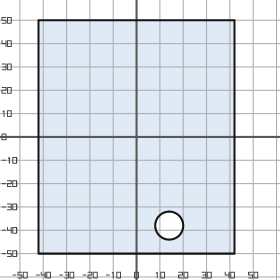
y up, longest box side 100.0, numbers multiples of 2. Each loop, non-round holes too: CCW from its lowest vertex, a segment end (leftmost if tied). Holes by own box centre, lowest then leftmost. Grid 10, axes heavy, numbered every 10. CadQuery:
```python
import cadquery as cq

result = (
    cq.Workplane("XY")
    .moveTo(-42.0, -50.0)
    .lineTo(42.0, -50.0)
    .lineTo(42.0, 50.0)
    .lineTo(-42.0, 50.0)
    .close()
    .moveTo(14.0, -38.0)
    .circle(6.0)
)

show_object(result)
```